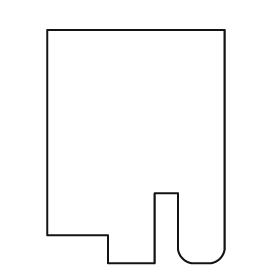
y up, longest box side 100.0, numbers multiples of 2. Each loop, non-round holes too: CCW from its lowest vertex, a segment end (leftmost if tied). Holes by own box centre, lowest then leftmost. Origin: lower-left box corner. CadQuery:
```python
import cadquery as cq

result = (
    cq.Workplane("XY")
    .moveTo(26.0, 0.0)
    .lineTo(46.0, 0.0)
    .lineTo(46.0, 30.0)
    .lineTo(56.0, 30.0)
    .lineTo(56.0, 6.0)
    .threePointArc((58.0, 2.0), (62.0, 0.0))
    .lineTo(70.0, 0.0)
    .threePointArc((74.0, 2.0), (76.0, 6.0))
    .lineTo(76.0, 100.0)
    .lineTo(0.0, 100.0)
    .lineTo(0.0, 12.0)
    .lineTo(26.0, 12.0)
    .close()
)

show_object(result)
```